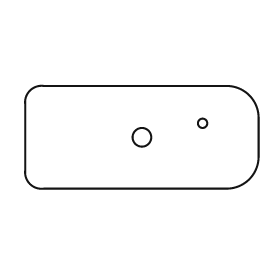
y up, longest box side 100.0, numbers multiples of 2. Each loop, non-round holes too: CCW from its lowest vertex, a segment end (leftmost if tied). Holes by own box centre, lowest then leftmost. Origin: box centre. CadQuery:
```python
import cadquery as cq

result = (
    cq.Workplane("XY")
    .moveTo(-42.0, -22.0)
    .lineTo(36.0, -22.0)
    .threePointArc((46.0, -18.0), (50.0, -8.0))
    .lineTo(50.0, 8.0)
    .threePointArc((46.0, 18.0), (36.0, 22.0))
    .lineTo(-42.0, 22.0)
    .threePointArc((-48.0, 20.0), (-50.0, 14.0))
    .lineTo(-50.0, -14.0)
    .threePointArc((-48.0, -20.0), (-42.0, -22.0))
    .close()
    .moveTo(0.0, 0.0)
    .circle(4.0)
    .moveTo(26.0, 6.0)
    .circle(2.0)
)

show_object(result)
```